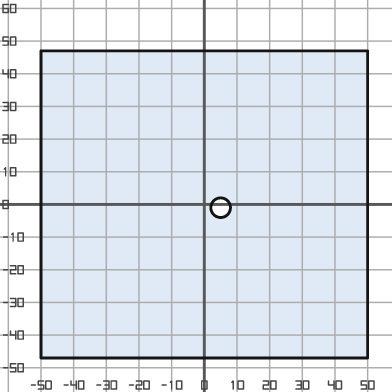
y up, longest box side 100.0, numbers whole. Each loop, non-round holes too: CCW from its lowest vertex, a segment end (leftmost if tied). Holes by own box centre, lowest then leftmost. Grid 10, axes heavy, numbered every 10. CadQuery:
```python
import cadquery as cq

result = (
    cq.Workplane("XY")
    .moveTo(-50.0, -47.0)
    .lineTo(50.0, -47.0)
    .lineTo(50.0, 47.0)
    .lineTo(-50.0, 47.0)
    .close()
    .moveTo(5.0, -1.0)
    .circle(3.0)
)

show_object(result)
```